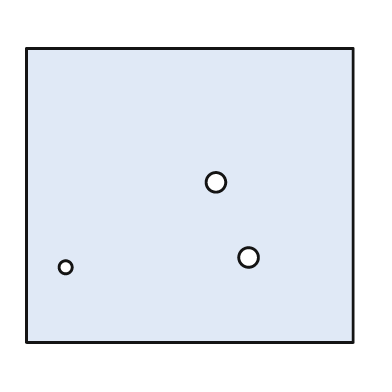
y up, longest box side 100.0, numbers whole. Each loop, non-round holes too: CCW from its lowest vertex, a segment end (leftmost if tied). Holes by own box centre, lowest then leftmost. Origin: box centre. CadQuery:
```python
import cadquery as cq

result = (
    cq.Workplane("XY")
    .moveTo(-50.0, -45.0)
    .lineTo(50.0, -45.0)
    .lineTo(50.0, 45.0)
    .lineTo(-50.0, 45.0)
    .close()
    .moveTo(-38.0, -22.0)
    .circle(2.0)
    .moveTo(18.0, -19.0)
    .circle(3.0)
    .moveTo(8.0, 4.0)
    .circle(3.0)
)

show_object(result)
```